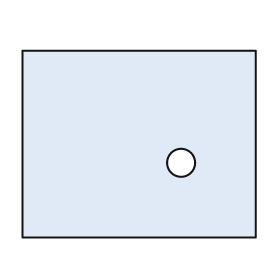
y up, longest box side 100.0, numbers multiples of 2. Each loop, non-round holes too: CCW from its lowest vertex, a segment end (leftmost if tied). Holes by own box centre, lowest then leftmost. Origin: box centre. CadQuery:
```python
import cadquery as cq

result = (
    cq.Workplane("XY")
    .moveTo(-50.0, -40.0)
    .lineTo(50.0, -40.0)
    .lineTo(50.0, 40.0)
    .lineTo(-50.0, 40.0)
    .close()
    .moveTo(18.0, -8.0)
    .circle(6.0)
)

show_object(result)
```